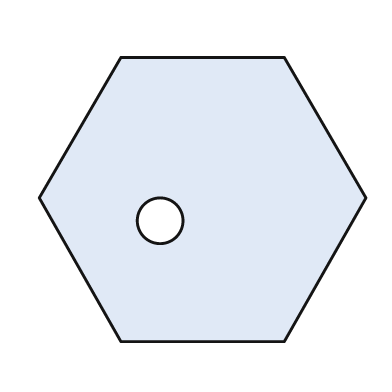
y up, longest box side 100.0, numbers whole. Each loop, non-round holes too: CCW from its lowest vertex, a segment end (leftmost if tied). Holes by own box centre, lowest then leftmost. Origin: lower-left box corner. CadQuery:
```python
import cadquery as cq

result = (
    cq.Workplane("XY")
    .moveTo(25.0, 0.0)
    .lineTo(75.0, 0.0)
    .lineTo(100.0, 44.0)
    .lineTo(75.0, 87.0)
    .lineTo(25.0, 87.0)
    .lineTo(0.0, 44.0)
    .close()
    .moveTo(37.0, 37.0)
    .circle(7.0)
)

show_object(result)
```